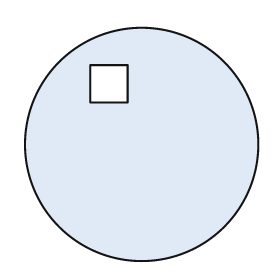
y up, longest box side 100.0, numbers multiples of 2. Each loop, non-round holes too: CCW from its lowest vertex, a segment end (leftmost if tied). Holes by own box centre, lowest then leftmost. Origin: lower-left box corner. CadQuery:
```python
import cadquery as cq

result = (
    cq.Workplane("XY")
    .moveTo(50.0, 50.0)
    .circle(50.0)
    .moveTo(28.0, 68.0)
    .lineTo(44.0, 68.0)
    .lineTo(44.0, 84.0)
    .lineTo(28.0, 84.0)
    .close()
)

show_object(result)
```